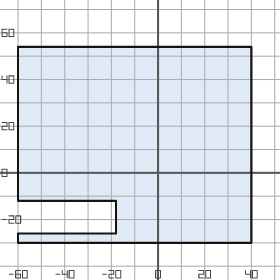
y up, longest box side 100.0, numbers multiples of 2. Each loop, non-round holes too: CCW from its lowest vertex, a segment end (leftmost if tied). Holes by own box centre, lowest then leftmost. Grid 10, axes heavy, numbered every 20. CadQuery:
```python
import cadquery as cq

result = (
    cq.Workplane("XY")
    .moveTo(-60.0, -30.0)
    .lineTo(40.0, -30.0)
    .lineTo(40.0, 54.0)
    .lineTo(-60.0, 54.0)
    .lineTo(-60.0, -12.0)
    .lineTo(-18.0, -12.0)
    .lineTo(-18.0, -26.0)
    .lineTo(-60.0, -26.0)
    .close()
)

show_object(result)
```